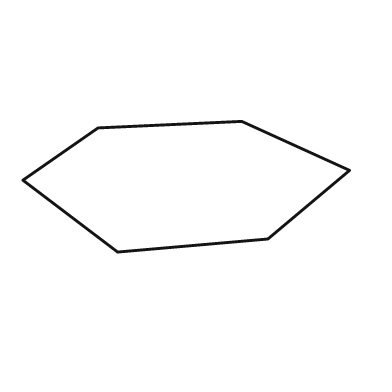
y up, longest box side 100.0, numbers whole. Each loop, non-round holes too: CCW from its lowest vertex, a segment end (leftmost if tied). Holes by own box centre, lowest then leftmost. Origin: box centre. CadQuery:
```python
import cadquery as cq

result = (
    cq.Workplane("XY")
    .moveTo(-21.0, -20.0)
    .lineTo(25.0, -16.0)
    .lineTo(50.0, 5.0)
    .lineTo(17.0, 20.0)
    .lineTo(-27.0, 18.0)
    .lineTo(-50.0, 2.0)
    .close()
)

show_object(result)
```